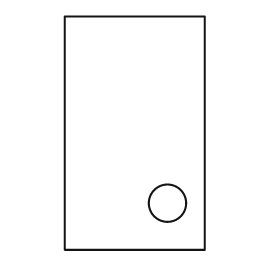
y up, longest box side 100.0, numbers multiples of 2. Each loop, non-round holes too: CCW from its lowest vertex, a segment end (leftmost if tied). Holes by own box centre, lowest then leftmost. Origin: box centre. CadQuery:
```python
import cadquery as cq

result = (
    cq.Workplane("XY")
    .moveTo(-30.0, -50.0)
    .lineTo(30.0, -50.0)
    .lineTo(30.0, 50.0)
    .lineTo(-30.0, 50.0)
    .close()
    .moveTo(14.0, -30.0)
    .circle(8.0)
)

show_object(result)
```